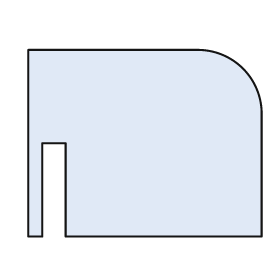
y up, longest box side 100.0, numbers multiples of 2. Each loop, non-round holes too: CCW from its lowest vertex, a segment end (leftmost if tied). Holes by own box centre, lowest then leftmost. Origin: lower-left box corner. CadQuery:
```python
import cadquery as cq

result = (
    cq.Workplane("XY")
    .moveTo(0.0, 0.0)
    .lineTo(6.0, 0.0)
    .lineTo(6.0, 40.0)
    .lineTo(16.0, 40.0)
    .lineTo(16.0, 0.0)
    .lineTo(100.0, 0.0)
    .lineTo(100.0, 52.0)
    .threePointArc((92.0, 72.0), (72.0, 80.0))
    .lineTo(0.0, 80.0)
    .close()
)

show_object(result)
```